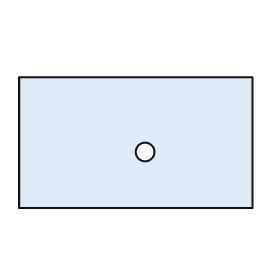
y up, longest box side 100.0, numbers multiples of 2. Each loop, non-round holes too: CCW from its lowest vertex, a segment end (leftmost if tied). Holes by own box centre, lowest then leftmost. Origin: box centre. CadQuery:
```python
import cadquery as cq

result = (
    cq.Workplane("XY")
    .moveTo(-50.0, -28.0)
    .lineTo(50.0, -28.0)
    .lineTo(50.0, 28.0)
    .lineTo(-50.0, 28.0)
    .close()
    .moveTo(4.0, -4.0)
    .circle(4.0)
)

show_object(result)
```